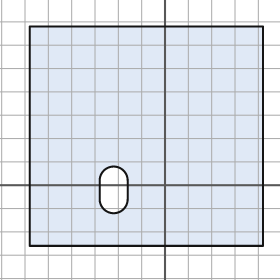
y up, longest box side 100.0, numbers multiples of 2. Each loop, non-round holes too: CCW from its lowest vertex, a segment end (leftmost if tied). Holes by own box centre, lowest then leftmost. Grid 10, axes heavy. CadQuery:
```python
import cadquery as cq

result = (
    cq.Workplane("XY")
    .moveTo(-58.0, -26.0)
    .lineTo(42.0, -26.0)
    .lineTo(42.0, 68.0)
    .lineTo(-58.0, 68.0)
    .close()
    .moveTo(-28.0, -6.0)
    .threePointArc((-22.0, -12.0), (-16.0, -6.0))
    .lineTo(-16.0, 2.0)
    .threePointArc((-22.0, 8.0), (-28.0, 2.0))
    .close()
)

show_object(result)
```